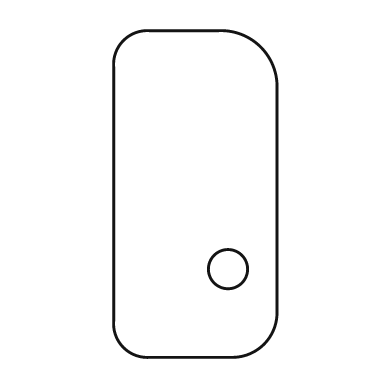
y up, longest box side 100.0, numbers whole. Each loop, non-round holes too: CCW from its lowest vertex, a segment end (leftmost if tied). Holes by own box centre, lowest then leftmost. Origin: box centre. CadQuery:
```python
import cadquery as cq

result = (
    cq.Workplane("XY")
    .moveTo(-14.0, -50.0)
    .lineTo(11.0, -50.0)
    .threePointArc((21.0, -46.0), (25.0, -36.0))
    .lineTo(25.0, 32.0)
    .threePointArc((20.0, 45.0), (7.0, 50.0))
    .lineTo(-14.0, 50.0)
    .threePointArc((-22.0, 47.0), (-25.0, 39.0))
    .lineTo(-25.0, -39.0)
    .threePointArc((-22.0, -47.0), (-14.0, -50.0))
    .close()
    .moveTo(10.0, -23.0)
    .circle(6.0)
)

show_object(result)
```